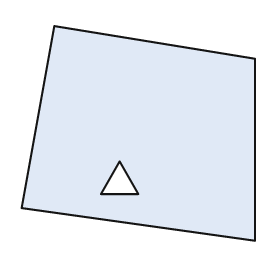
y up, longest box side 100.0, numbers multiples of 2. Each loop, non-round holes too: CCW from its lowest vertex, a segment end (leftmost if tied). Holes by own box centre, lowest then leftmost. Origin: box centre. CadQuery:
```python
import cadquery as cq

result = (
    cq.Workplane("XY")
    .moveTo(50.0, -46.0)
    .lineTo(50.0, 32.0)
    .lineTo(-36.0, 46.0)
    .lineTo(-50.0, -32.0)
    .close()
    .moveTo(-16.0, -26.0)
    .lineTo(0.0, -26.0)
    .lineTo(-8.0, -12.0)
    .close()
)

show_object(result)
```